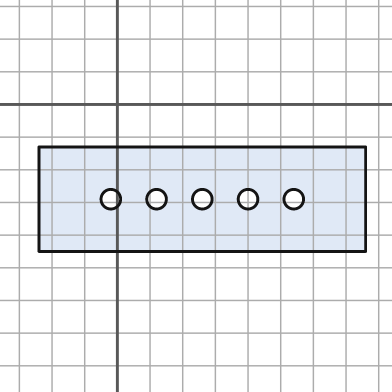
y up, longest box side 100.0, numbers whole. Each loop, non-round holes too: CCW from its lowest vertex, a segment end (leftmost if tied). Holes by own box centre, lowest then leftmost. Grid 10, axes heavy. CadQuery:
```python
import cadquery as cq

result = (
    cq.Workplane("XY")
    .moveTo(-24.0, -45.0)
    .lineTo(76.0, -45.0)
    .lineTo(76.0, -13.0)
    .lineTo(-24.0, -13.0)
    .close()
    .moveTo(-2.0, -29.0)
    .circle(3.0)
    .moveTo(12.0, -29.0)
    .circle(3.0)
    .moveTo(26.0, -29.0)
    .circle(3.0)
    .moveTo(40.0, -29.0)
    .circle(3.0)
    .moveTo(54.0, -29.0)
    .circle(3.0)
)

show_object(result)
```